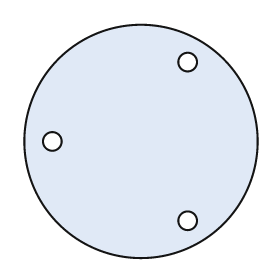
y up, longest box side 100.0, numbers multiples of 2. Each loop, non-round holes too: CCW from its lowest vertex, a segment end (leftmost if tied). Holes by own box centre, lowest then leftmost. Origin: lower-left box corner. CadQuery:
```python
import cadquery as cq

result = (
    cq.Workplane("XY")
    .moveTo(50.0, 50.0)
    .circle(50.0)
    .moveTo(70.0, 16.0)
    .circle(4.0)
    .moveTo(12.0, 50.0)
    .circle(4.0)
    .moveTo(70.0, 84.0)
    .circle(4.0)
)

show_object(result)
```